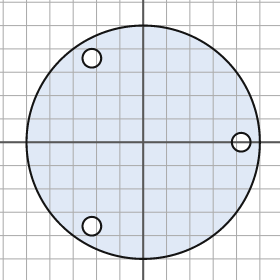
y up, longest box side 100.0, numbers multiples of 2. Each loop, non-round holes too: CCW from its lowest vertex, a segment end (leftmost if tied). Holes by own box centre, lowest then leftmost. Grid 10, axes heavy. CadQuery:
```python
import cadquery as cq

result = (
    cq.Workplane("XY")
    .moveTo(0.0, 0.0)
    .circle(50.0)
    .moveTo(-22.0, -36.0)
    .circle(4.0)
    .moveTo(42.0, 0.0)
    .circle(4.0)
    .moveTo(-22.0, 36.0)
    .circle(4.0)
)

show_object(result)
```